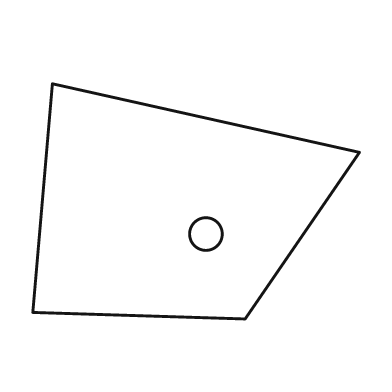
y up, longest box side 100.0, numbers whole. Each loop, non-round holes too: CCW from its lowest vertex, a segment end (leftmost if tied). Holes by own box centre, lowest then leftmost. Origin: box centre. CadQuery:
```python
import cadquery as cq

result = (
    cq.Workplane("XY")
    .moveTo(15.0, -36.0)
    .lineTo(50.0, 15.0)
    .lineTo(-44.0, 36.0)
    .lineTo(-50.0, -34.0)
    .close()
    .moveTo(3.0, -10.0)
    .circle(5.0)
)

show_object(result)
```